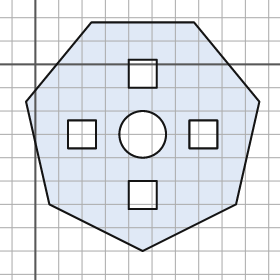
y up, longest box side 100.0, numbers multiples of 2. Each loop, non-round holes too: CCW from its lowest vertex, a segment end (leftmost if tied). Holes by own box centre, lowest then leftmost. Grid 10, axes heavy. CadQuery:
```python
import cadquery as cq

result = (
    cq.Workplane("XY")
    .moveTo(46.0, -80.0)
    .lineTo(86.0, -60.0)
    .lineTo(96.0, -16.0)
    .lineTo(68.0, 18.0)
    .lineTo(24.0, 18.0)
    .lineTo(-4.0, -16.0)
    .lineTo(6.0, -60.0)
    .close()
    .moveTo(40.0, -62.0)
    .lineTo(52.0, -62.0)
    .lineTo(52.0, -50.0)
    .lineTo(40.0, -50.0)
    .close()
    .moveTo(14.0, -36.0)
    .lineTo(26.0, -36.0)
    .lineTo(26.0, -24.0)
    .lineTo(14.0, -24.0)
    .close()
    .moveTo(46.0, -30.0)
    .circle(10.0)
    .moveTo(66.0, -36.0)
    .lineTo(78.0, -36.0)
    .lineTo(78.0, -24.0)
    .lineTo(66.0, -24.0)
    .close()
    .moveTo(40.0, -10.0)
    .lineTo(52.0, -10.0)
    .lineTo(52.0, 2.0)
    .lineTo(40.0, 2.0)
    .close()
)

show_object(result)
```